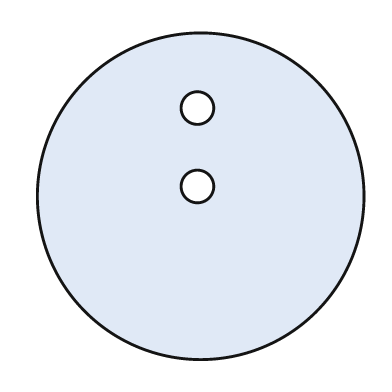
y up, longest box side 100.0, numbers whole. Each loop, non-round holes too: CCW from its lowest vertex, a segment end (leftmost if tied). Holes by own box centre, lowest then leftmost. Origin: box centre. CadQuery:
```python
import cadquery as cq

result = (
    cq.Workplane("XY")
    .moveTo(0.0, 0.0)
    .circle(50.0)
    .moveTo(-1.0, 3.0)
    .circle(5.0)
    .moveTo(-1.0, 27.0)
    .circle(5.0)
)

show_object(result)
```